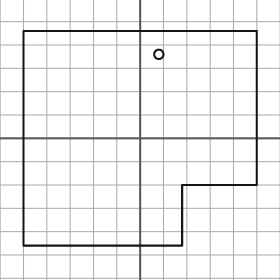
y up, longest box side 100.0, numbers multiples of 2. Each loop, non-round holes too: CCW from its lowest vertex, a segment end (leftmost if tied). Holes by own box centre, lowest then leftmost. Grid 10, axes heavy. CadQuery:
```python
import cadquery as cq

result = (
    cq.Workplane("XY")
    .moveTo(-50.0, -46.0)
    .lineTo(18.0, -46.0)
    .lineTo(18.0, -20.0)
    .lineTo(50.0, -20.0)
    .lineTo(50.0, 46.0)
    .lineTo(-50.0, 46.0)
    .close()
    .moveTo(8.0, 36.0)
    .circle(2.0)
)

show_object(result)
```